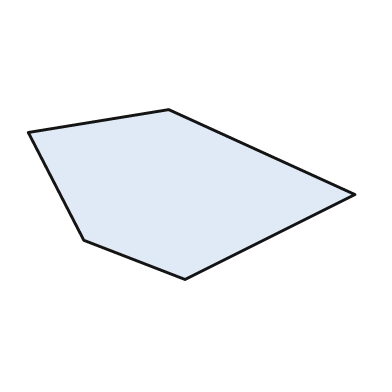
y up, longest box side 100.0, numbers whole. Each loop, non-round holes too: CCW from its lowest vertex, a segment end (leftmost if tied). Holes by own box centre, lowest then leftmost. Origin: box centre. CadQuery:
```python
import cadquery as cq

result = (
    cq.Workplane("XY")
    .moveTo(-2.0, -26.0)
    .lineTo(50.0, 0.0)
    .lineTo(-7.0, 26.0)
    .lineTo(-50.0, 19.0)
    .lineTo(-33.0, -14.0)
    .close()
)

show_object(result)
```